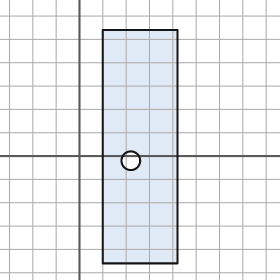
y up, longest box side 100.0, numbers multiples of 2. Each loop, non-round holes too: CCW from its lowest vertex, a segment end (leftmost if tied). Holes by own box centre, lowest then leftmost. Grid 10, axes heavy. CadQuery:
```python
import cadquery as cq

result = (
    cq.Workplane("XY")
    .moveTo(10.0, -46.0)
    .lineTo(42.0, -46.0)
    .lineTo(42.0, 54.0)
    .lineTo(10.0, 54.0)
    .close()
    .moveTo(22.0, -2.0)
    .circle(4.0)
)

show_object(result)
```